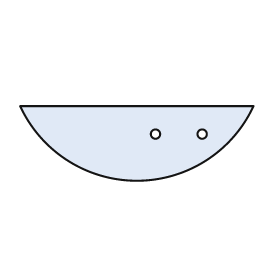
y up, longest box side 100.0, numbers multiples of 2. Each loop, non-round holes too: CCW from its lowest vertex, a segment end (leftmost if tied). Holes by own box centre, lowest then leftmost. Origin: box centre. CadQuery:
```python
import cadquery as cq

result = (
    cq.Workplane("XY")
    .moveTo(-50.0, 16.0)
    .threePointArc((0.0, -16.0), (50.0, 16.0))
    .close()
    .moveTo(8.0, 4.0)
    .circle(2.0)
    .moveTo(28.0, 4.0)
    .circle(2.0)
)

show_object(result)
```